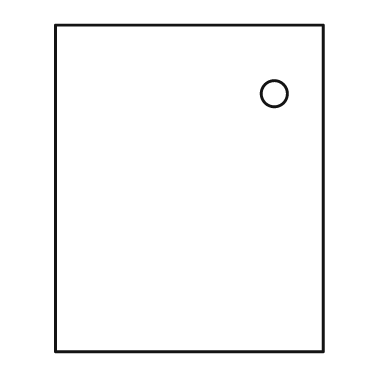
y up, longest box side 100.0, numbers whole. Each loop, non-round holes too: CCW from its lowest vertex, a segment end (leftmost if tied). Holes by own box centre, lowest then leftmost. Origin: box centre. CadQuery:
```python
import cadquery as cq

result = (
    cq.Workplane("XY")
    .moveTo(-41.0, -50.0)
    .lineTo(41.0, -50.0)
    .lineTo(41.0, 50.0)
    .lineTo(-41.0, 50.0)
    .close()
    .moveTo(26.0, 29.0)
    .circle(4.0)
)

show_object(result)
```